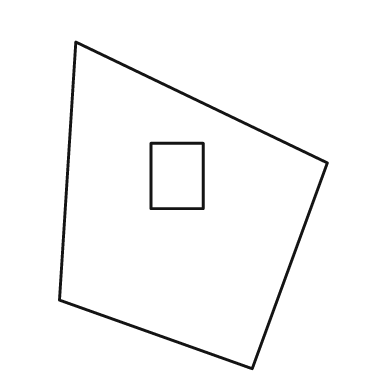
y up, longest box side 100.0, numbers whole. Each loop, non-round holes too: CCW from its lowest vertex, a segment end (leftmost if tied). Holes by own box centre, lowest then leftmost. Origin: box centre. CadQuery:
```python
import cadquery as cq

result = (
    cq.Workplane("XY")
    .moveTo(18.0, -50.0)
    .lineTo(41.0, 13.0)
    .lineTo(-36.0, 50.0)
    .lineTo(-41.0, -29.0)
    .close()
    .moveTo(-13.0, -1.0)
    .lineTo(3.0, -1.0)
    .lineTo(3.0, 19.0)
    .lineTo(-13.0, 19.0)
    .close()
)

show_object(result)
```